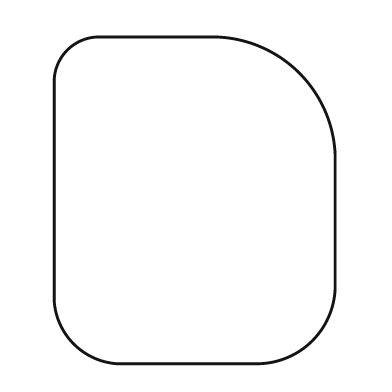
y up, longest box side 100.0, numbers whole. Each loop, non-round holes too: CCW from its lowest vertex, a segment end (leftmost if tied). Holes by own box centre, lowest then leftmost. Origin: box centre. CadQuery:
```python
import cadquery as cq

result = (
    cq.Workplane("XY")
    .moveTo(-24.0, -50.0)
    .lineTo(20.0, -50.0)
    .threePointArc((36.0, -43.0), (43.0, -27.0))
    .lineTo(43.0, 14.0)
    .threePointArc((32.0, 39.0), (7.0, 50.0))
    .lineTo(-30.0, 50.0)
    .threePointArc((-39.0, 46.0), (-43.0, 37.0))
    .lineTo(-43.0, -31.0)
    .threePointArc((-37.0, -44.0), (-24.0, -50.0))
    .close()
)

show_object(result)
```